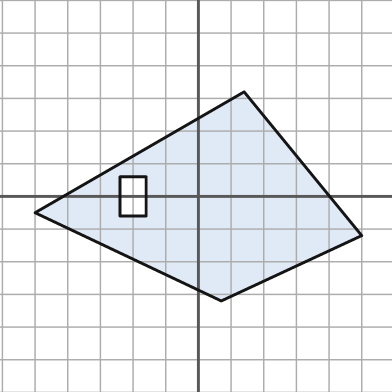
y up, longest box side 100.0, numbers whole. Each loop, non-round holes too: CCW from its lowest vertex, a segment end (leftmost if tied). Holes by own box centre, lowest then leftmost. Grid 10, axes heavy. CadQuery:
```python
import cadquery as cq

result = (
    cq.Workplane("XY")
    .moveTo(7.0, -32.0)
    .lineTo(50.0, -12.0)
    .lineTo(14.0, 32.0)
    .lineTo(-50.0, -5.0)
    .close()
    .moveTo(-24.0, -6.0)
    .lineTo(-16.0, -6.0)
    .lineTo(-16.0, 6.0)
    .lineTo(-24.0, 6.0)
    .close()
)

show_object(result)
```